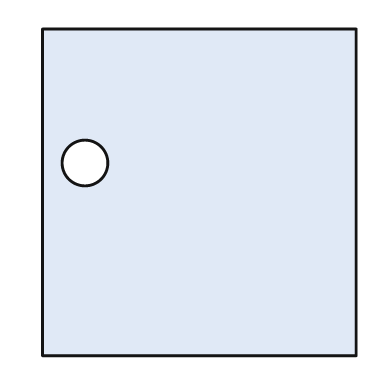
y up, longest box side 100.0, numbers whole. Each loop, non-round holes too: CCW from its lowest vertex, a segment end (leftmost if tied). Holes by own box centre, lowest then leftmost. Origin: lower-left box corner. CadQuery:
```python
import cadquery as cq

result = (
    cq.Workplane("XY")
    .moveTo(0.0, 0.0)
    .lineTo(96.0, 0.0)
    .lineTo(96.0, 100.0)
    .lineTo(0.0, 100.0)
    .close()
    .moveTo(13.0, 59.0)
    .circle(7.0)
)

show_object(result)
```